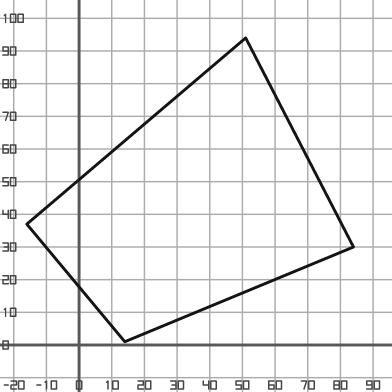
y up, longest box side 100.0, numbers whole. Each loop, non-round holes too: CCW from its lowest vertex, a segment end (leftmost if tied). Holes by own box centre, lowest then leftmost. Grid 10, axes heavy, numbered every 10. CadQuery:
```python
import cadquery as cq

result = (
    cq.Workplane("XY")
    .moveTo(14.0, 1.0)
    .lineTo(84.0, 30.0)
    .lineTo(51.0, 94.0)
    .lineTo(-16.0, 37.0)
    .close()
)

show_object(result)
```